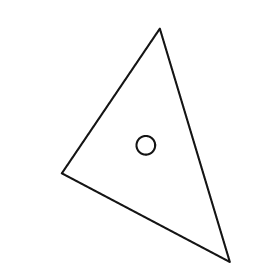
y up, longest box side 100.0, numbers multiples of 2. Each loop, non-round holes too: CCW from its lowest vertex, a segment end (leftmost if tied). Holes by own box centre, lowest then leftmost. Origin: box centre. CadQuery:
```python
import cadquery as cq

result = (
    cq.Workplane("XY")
    .moveTo(36.0, -50.0)
    .lineTo(6.0, 50.0)
    .lineTo(-36.0, -12.0)
    .close()
    .moveTo(0.0, 0.0)
    .circle(4.0)
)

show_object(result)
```